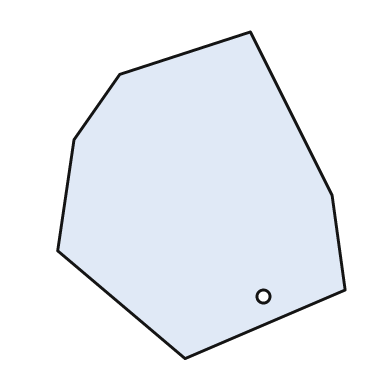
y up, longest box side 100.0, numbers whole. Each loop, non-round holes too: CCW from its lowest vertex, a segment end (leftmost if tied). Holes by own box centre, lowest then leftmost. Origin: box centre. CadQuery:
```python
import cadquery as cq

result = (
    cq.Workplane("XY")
    .moveTo(-5.0, -50.0)
    .lineTo(44.0, -29.0)
    .lineTo(40.0, 0.0)
    .lineTo(15.0, 50.0)
    .lineTo(-25.0, 37.0)
    .lineTo(-39.0, 17.0)
    .lineTo(-44.0, -17.0)
    .close()
    .moveTo(19.0, -31.0)
    .circle(2.0)
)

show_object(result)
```